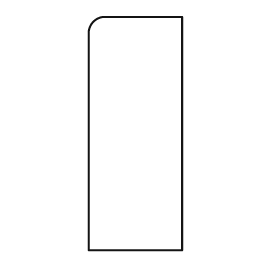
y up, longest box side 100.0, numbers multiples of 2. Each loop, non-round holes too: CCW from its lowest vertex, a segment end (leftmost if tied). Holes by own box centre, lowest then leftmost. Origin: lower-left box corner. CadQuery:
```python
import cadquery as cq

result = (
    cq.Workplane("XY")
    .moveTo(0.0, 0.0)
    .lineTo(40.0, 0.0)
    .lineTo(40.0, 100.0)
    .lineTo(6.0, 100.0)
    .threePointArc((2.0, 98.0), (0.0, 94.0))
    .close()
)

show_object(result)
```